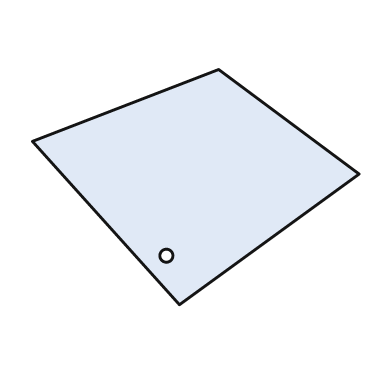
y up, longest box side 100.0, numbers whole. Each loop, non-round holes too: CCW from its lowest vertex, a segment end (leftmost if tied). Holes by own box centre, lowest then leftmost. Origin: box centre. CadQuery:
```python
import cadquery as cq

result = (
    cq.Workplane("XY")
    .moveTo(-5.0, -36.0)
    .lineTo(50.0, 4.0)
    .lineTo(7.0, 36.0)
    .lineTo(-50.0, 14.0)
    .close()
    .moveTo(-9.0, -21.0)
    .circle(2.0)
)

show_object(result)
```